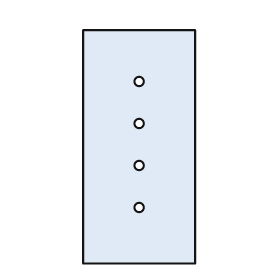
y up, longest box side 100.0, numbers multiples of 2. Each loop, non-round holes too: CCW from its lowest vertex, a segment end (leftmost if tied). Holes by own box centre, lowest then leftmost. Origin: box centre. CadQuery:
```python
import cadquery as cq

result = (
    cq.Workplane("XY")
    .moveTo(-24.0, -50.0)
    .lineTo(24.0, -50.0)
    .lineTo(24.0, 50.0)
    .lineTo(-24.0, 50.0)
    .close()
    .moveTo(0.0, -26.0)
    .circle(2.0)
    .moveTo(0.0, -8.0)
    .circle(2.0)
    .moveTo(0.0, 10.0)
    .circle(2.0)
    .moveTo(0.0, 28.0)
    .circle(2.0)
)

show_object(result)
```